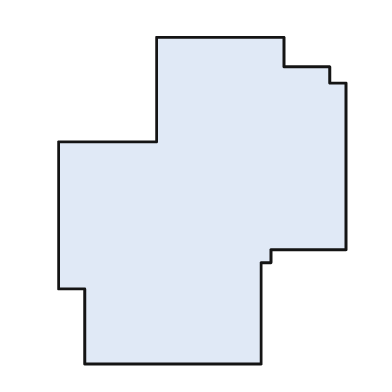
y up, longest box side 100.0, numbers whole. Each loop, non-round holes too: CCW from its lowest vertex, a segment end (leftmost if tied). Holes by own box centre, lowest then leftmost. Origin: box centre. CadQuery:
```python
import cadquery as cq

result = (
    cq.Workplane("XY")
    .moveTo(-36.0, -50.0)
    .lineTo(18.0, -50.0)
    .lineTo(18.0, -19.0)
    .lineTo(21.0, -19.0)
    .lineTo(21.0, -15.0)
    .lineTo(44.0, -15.0)
    .lineTo(44.0, 36.0)
    .lineTo(39.0, 36.0)
    .lineTo(39.0, 41.0)
    .lineTo(25.0, 41.0)
    .lineTo(25.0, 50.0)
    .lineTo(-14.0, 50.0)
    .lineTo(-14.0, 18.0)
    .lineTo(-44.0, 18.0)
    .lineTo(-44.0, -27.0)
    .lineTo(-36.0, -27.0)
    .close()
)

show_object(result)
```